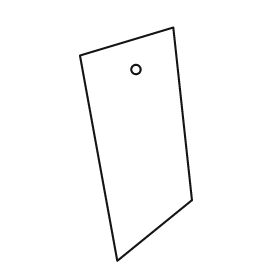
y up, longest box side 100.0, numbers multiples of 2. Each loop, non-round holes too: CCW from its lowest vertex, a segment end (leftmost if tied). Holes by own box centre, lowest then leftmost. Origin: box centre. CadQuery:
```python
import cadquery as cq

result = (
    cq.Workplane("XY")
    .moveTo(-8.0, -50.0)
    .lineTo(24.0, -24.0)
    .lineTo(16.0, 50.0)
    .lineTo(-24.0, 38.0)
    .close()
    .moveTo(0.0, 32.0)
    .circle(2.0)
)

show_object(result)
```